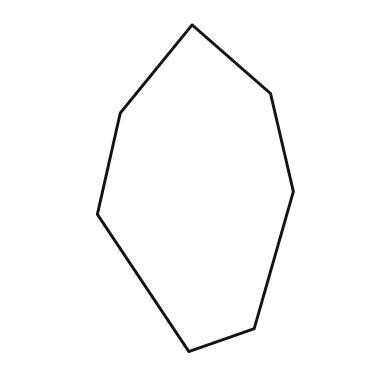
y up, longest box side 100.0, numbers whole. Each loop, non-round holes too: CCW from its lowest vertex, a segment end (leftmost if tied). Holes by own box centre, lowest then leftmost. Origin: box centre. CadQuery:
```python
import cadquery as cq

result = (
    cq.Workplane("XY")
    .moveTo(-2.0, -50.0)
    .lineTo(18.0, -43.0)
    .lineTo(30.0, -1.0)
    .lineTo(23.0, 29.0)
    .lineTo(-1.0, 50.0)
    .lineTo(-23.0, 23.0)
    .lineTo(-30.0, -8.0)
    .close()
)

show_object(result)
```